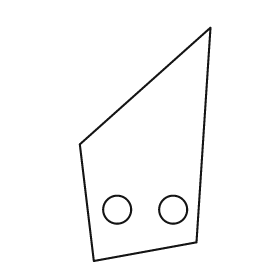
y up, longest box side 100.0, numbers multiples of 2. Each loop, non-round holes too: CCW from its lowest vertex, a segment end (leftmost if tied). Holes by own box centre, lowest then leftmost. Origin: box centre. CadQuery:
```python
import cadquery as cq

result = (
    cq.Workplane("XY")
    .moveTo(-22.0, -50.0)
    .lineTo(22.0, -42.0)
    .lineTo(28.0, 50.0)
    .lineTo(-28.0, 0.0)
    .close()
    .moveTo(-12.0, -28.0)
    .circle(6.0)
    .moveTo(12.0, -28.0)
    .circle(6.0)
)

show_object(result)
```